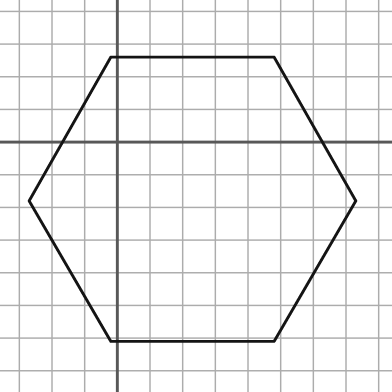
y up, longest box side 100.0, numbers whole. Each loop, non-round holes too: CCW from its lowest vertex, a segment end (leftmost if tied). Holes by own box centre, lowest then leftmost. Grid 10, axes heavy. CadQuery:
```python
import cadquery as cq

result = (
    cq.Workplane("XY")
    .moveTo(-2.0, -61.0)
    .lineTo(48.0, -61.0)
    .lineTo(73.0, -18.0)
    .lineTo(48.0, 26.0)
    .lineTo(-2.0, 26.0)
    .lineTo(-27.0, -18.0)
    .close()
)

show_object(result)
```